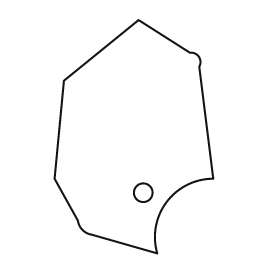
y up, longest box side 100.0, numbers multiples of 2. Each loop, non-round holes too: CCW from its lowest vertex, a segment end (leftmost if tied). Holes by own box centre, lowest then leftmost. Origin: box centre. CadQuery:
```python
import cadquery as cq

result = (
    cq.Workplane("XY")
    .moveTo(10.0, -50.0)
    .threePointArc((14.0, -28.0), (34.0, -18.0))
    .lineTo(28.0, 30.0)
    .threePointArc((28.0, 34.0), (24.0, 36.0))
    .lineTo(2.0, 50.0)
    .lineTo(-30.0, 24.0)
    .lineTo(-34.0, -18.0)
    .lineTo(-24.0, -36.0)
    .threePointArc((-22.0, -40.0), (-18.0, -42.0))
    .close()
    .moveTo(4.0, -24.0)
    .circle(4.0)
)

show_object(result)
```